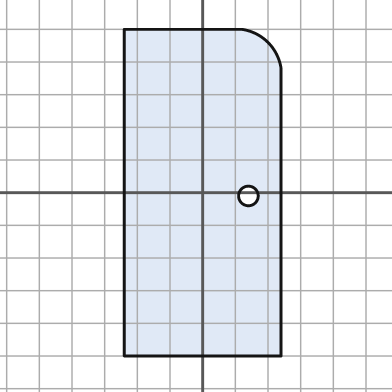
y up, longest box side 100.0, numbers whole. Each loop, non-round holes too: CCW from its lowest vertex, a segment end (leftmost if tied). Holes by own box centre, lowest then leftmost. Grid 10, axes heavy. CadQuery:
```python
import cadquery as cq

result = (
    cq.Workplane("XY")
    .moveTo(-24.0, -50.0)
    .lineTo(24.0, -50.0)
    .lineTo(24.0, 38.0)
    .threePointArc((20.0, 46.0), (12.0, 50.0))
    .lineTo(-24.0, 50.0)
    .close()
    .moveTo(14.0, -1.0)
    .circle(3.0)
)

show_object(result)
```